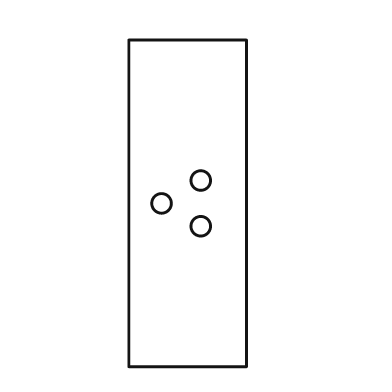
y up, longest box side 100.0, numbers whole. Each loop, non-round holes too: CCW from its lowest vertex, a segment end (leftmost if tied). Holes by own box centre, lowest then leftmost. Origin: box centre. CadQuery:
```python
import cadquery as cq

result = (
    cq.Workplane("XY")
    .moveTo(-18.0, -50.0)
    .lineTo(18.0, -50.0)
    .lineTo(18.0, 50.0)
    .lineTo(-18.0, 50.0)
    .close()
    .moveTo(4.0, -7.0)
    .circle(3.0)
    .moveTo(-8.0, 0.0)
    .circle(3.0)
    .moveTo(4.0, 7.0)
    .circle(3.0)
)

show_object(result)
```